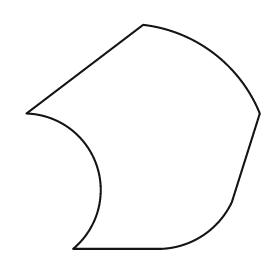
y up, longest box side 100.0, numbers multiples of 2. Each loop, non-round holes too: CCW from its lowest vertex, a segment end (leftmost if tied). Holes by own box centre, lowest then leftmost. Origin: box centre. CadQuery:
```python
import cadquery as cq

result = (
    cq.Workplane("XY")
    .moveTo(-30.0, -48.0)
    .lineTo(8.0, -48.0)
    .threePointArc((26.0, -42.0), (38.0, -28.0))
    .lineTo(50.0, 10.0)
    .threePointArc((30.0, 36.0), (0.0, 48.0))
    .lineTo(-50.0, 10.0)
    .threePointArc((-20.0, -12.0), (-30.0, -48.0))
    .close()
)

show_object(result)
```